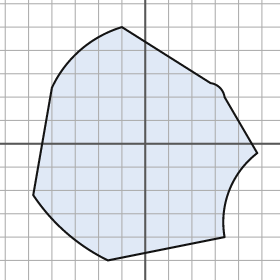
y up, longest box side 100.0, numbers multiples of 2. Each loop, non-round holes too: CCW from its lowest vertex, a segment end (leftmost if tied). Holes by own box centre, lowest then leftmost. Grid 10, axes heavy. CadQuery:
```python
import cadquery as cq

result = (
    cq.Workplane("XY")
    .moveTo(-16.0, -50.0)
    .lineTo(34.0, -40.0)
    .threePointArc((36.0, -20.0), (48.0, -4.0))
    .lineTo(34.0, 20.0)
    .threePointArc((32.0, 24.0), (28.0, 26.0))
    .lineTo(-10.0, 50.0)
    .threePointArc((-28.0, 40.0), (-40.0, 24.0))
    .lineTo(-48.0, -22.0)
    .threePointArc((-34.0, -38.0), (-16.0, -50.0))
    .close()
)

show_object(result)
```